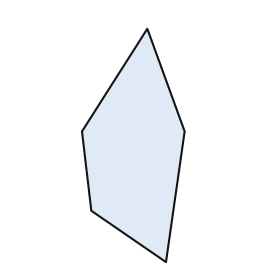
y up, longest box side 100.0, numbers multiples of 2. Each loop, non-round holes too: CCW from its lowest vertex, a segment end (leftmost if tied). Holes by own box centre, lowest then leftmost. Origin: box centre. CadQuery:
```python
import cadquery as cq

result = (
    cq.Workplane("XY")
    .moveTo(14.0, -50.0)
    .lineTo(22.0, 6.0)
    .lineTo(6.0, 50.0)
    .lineTo(-22.0, 6.0)
    .lineTo(-18.0, -28.0)
    .close()
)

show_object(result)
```